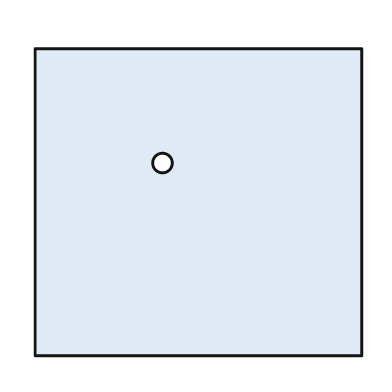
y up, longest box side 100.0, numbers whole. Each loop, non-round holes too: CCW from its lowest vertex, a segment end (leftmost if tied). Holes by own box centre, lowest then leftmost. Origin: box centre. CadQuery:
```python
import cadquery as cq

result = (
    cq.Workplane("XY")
    .moveTo(-50.0, -47.0)
    .lineTo(50.0, -47.0)
    .lineTo(50.0, 47.0)
    .lineTo(-50.0, 47.0)
    .close()
    .moveTo(-11.0, 12.0)
    .circle(3.0)
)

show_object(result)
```